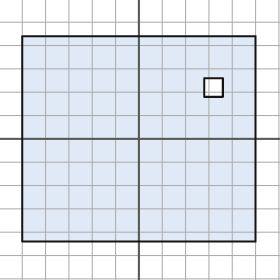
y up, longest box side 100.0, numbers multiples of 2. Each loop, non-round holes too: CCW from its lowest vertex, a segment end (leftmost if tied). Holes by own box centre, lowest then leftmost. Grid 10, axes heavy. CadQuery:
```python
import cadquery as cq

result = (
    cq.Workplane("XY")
    .moveTo(-50.0, -44.0)
    .lineTo(50.0, -44.0)
    .lineTo(50.0, 44.0)
    .lineTo(-50.0, 44.0)
    .close()
    .moveTo(28.0, 18.0)
    .lineTo(36.0, 18.0)
    .lineTo(36.0, 26.0)
    .lineTo(28.0, 26.0)
    .close()
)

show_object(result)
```